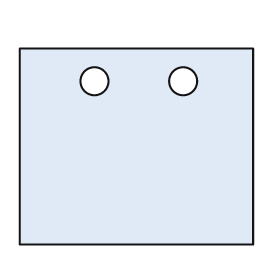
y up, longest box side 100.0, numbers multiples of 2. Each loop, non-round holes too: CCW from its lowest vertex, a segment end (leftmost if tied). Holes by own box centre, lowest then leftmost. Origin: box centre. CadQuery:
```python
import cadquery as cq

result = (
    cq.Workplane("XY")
    .moveTo(-50.0, -42.0)
    .lineTo(50.0, -42.0)
    .lineTo(50.0, 42.0)
    .lineTo(-50.0, 42.0)
    .close()
    .moveTo(-18.0, 28.0)
    .circle(6.0)
    .moveTo(20.0, 28.0)
    .circle(6.0)
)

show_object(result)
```